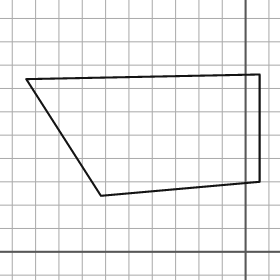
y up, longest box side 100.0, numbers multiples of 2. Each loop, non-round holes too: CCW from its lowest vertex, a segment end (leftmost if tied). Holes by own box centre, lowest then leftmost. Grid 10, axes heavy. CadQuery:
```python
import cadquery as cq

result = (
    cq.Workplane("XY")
    .moveTo(-62.0, 24.0)
    .lineTo(6.0, 30.0)
    .lineTo(6.0, 76.0)
    .lineTo(-94.0, 74.0)
    .close()
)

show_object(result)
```